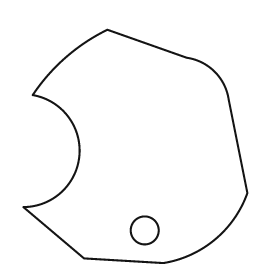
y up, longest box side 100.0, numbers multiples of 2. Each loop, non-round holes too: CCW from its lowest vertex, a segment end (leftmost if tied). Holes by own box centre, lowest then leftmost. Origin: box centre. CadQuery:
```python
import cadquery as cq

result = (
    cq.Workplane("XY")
    .moveTo(12.0, -50.0)
    .threePointArc((34.0, -40.0), (48.0, -20.0))
    .lineTo(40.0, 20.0)
    .threePointArc((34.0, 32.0), (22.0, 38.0))
    .lineTo(-12.0, 50.0)
    .threePointArc((-30.0, 38.0), (-44.0, 22.0))
    .threePointArc((-24.0, -4.0), (-48.0, -26.0))
    .lineTo(-22.0, -48.0)
    .close()
    .moveTo(4.0, -36.0)
    .circle(6.0)
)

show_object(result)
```